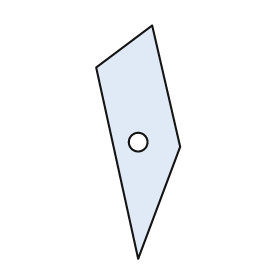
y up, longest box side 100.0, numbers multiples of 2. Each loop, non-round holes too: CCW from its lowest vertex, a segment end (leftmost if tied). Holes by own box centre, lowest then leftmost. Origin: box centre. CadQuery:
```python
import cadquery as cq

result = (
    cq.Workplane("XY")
    .moveTo(0.0, -50.0)
    .lineTo(18.0, -2.0)
    .lineTo(6.0, 50.0)
    .lineTo(-18.0, 32.0)
    .close()
    .moveTo(0.0, 0.0)
    .circle(4.0)
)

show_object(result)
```